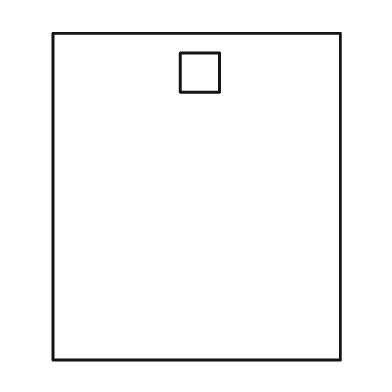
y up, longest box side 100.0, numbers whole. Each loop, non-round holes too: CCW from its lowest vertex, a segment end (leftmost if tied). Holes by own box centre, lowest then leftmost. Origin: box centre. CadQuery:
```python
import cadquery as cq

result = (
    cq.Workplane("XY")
    .moveTo(-44.0, -50.0)
    .lineTo(44.0, -50.0)
    .lineTo(44.0, 50.0)
    .lineTo(-44.0, 50.0)
    .close()
    .moveTo(-5.0, 32.0)
    .lineTo(7.0, 32.0)
    .lineTo(7.0, 44.0)
    .lineTo(-5.0, 44.0)
    .close()
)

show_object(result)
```